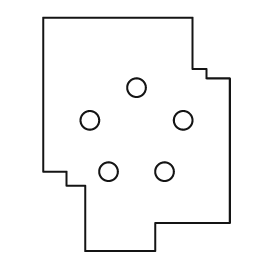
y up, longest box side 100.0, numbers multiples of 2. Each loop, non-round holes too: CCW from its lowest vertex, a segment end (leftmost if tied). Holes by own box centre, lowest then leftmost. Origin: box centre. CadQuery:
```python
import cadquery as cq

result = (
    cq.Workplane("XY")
    .moveTo(-22.0, -50.0)
    .lineTo(8.0, -50.0)
    .lineTo(8.0, -38.0)
    .lineTo(40.0, -38.0)
    .lineTo(40.0, 24.0)
    .lineTo(30.0, 24.0)
    .lineTo(30.0, 28.0)
    .lineTo(24.0, 28.0)
    .lineTo(24.0, 50.0)
    .lineTo(-40.0, 50.0)
    .lineTo(-40.0, -16.0)
    .lineTo(-30.0, -16.0)
    .lineTo(-30.0, -22.0)
    .lineTo(-22.0, -22.0)
    .close()
    .moveTo(-12.0, -16.0)
    .circle(4.0)
    .moveTo(12.0, -16.0)
    .circle(4.0)
    .moveTo(-20.0, 6.0)
    .circle(4.0)
    .moveTo(20.0, 6.0)
    .circle(4.0)
    .moveTo(0.0, 20.0)
    .circle(4.0)
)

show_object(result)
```